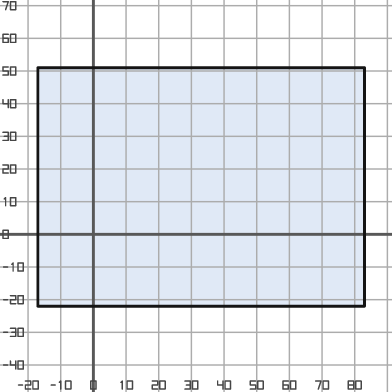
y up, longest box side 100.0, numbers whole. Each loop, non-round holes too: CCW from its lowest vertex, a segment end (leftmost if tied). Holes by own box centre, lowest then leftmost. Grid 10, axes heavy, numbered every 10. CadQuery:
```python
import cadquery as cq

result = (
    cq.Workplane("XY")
    .moveTo(-17.0, -22.0)
    .lineTo(83.0, -22.0)
    .lineTo(83.0, 51.0)
    .lineTo(-17.0, 51.0)
    .close()
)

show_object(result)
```